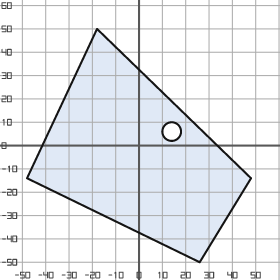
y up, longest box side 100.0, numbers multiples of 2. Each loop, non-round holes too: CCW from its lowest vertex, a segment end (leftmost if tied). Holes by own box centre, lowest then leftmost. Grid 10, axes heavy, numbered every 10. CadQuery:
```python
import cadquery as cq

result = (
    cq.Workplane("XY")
    .moveTo(26.0, -50.0)
    .lineTo(48.0, -14.0)
    .lineTo(-18.0, 50.0)
    .lineTo(-48.0, -14.0)
    .close()
    .moveTo(14.0, 6.0)
    .circle(4.0)
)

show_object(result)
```